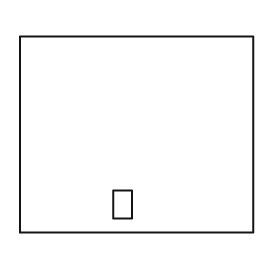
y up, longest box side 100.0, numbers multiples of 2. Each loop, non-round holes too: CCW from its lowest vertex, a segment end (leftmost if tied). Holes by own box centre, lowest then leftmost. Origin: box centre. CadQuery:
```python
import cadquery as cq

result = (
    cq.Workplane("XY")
    .moveTo(-50.0, -42.0)
    .lineTo(50.0, -42.0)
    .lineTo(50.0, 42.0)
    .lineTo(-50.0, 42.0)
    .close()
    .moveTo(-10.0, -36.0)
    .lineTo(-2.0, -36.0)
    .lineTo(-2.0, -24.0)
    .lineTo(-10.0, -24.0)
    .close()
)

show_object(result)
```